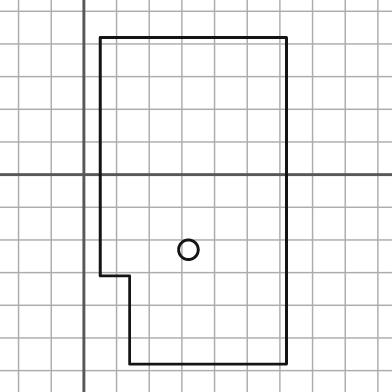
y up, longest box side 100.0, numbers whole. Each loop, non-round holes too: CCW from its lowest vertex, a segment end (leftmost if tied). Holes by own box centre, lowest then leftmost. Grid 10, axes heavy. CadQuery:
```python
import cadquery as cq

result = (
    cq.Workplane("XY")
    .moveTo(14.0, -58.0)
    .lineTo(62.0, -58.0)
    .lineTo(62.0, 42.0)
    .lineTo(5.0, 42.0)
    .lineTo(5.0, -31.0)
    .lineTo(14.0, -31.0)
    .close()
    .moveTo(32.0, -23.0)
    .circle(3.0)
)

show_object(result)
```